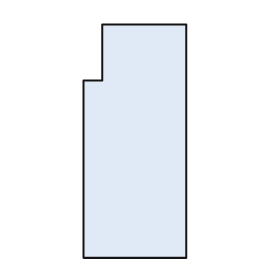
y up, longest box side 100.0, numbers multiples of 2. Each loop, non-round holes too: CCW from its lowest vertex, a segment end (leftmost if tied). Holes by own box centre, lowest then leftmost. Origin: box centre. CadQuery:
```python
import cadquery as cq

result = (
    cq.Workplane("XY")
    .moveTo(-22.0, -50.0)
    .lineTo(22.0, -50.0)
    .lineTo(22.0, 50.0)
    .lineTo(-14.0, 50.0)
    .lineTo(-14.0, 26.0)
    .lineTo(-22.0, 26.0)
    .close()
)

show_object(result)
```